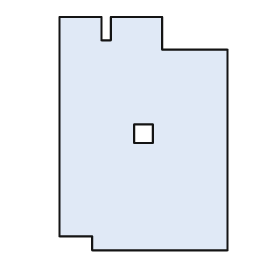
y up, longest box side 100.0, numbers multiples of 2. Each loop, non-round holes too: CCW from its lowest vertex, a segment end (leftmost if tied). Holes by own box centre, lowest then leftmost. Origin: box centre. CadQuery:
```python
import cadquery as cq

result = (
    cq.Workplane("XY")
    .moveTo(-22.0, -50.0)
    .lineTo(36.0, -50.0)
    .lineTo(36.0, 36.0)
    .lineTo(8.0, 36.0)
    .lineTo(8.0, 50.0)
    .lineTo(-14.0, 50.0)
    .lineTo(-14.0, 40.0)
    .lineTo(-18.0, 40.0)
    .lineTo(-18.0, 50.0)
    .lineTo(-36.0, 50.0)
    .lineTo(-36.0, -44.0)
    .lineTo(-22.0, -44.0)
    .close()
    .moveTo(-4.0, -4.0)
    .lineTo(4.0, -4.0)
    .lineTo(4.0, 4.0)
    .lineTo(-4.0, 4.0)
    .close()
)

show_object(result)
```